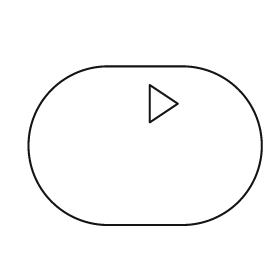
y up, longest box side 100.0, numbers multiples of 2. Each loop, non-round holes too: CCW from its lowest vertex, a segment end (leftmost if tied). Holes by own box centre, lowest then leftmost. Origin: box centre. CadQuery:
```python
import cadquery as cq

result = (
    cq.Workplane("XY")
    .moveTo(-16.0, -34.0)
    .lineTo(16.0, -34.0)
    .threePointArc((50.0, 0.0), (16.0, 34.0))
    .lineTo(-16.0, 34.0)
    .threePointArc((-50.0, 0.0), (-16.0, -34.0))
    .close()
    .moveTo(2.0, 10.0)
    .lineTo(14.0, 18.0)
    .lineTo(2.0, 26.0)
    .close()
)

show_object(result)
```